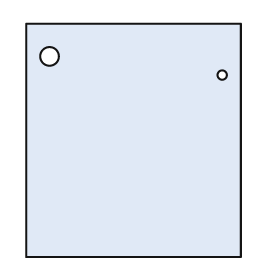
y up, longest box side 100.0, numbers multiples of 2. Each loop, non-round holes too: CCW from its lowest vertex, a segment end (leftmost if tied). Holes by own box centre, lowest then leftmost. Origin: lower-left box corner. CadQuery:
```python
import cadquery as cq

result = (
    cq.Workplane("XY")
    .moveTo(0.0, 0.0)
    .lineTo(92.0, 0.0)
    .lineTo(92.0, 100.0)
    .lineTo(0.0, 100.0)
    .close()
    .moveTo(84.0, 78.0)
    .circle(2.0)
    .moveTo(10.0, 86.0)
    .circle(4.0)
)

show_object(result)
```